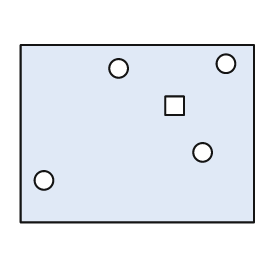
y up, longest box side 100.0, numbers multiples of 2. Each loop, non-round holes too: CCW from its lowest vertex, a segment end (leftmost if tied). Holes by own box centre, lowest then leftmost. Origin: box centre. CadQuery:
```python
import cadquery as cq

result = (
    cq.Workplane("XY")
    .moveTo(-50.0, -38.0)
    .lineTo(50.0, -38.0)
    .lineTo(50.0, 38.0)
    .lineTo(-50.0, 38.0)
    .close()
    .moveTo(-40.0, -20.0)
    .circle(4.0)
    .moveTo(28.0, -8.0)
    .circle(4.0)
    .moveTo(12.0, 8.0)
    .lineTo(20.0, 8.0)
    .lineTo(20.0, 16.0)
    .lineTo(12.0, 16.0)
    .close()
    .moveTo(-8.0, 28.0)
    .circle(4.0)
    .moveTo(38.0, 30.0)
    .circle(4.0)
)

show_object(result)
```